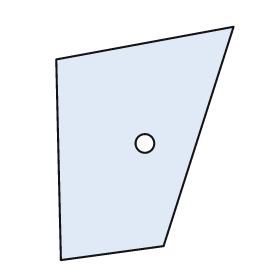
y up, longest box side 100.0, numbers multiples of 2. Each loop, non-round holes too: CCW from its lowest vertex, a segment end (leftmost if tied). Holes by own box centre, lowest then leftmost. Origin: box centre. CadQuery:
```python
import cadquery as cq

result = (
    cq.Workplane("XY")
    .moveTo(-36.0, -50.0)
    .lineTo(8.0, -44.0)
    .lineTo(38.0, 50.0)
    .lineTo(-38.0, 36.0)
    .close()
    .moveTo(0.0, 0.0)
    .circle(4.0)
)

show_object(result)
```